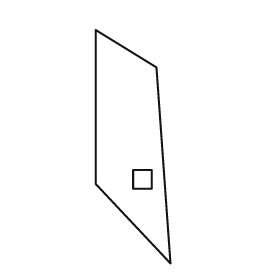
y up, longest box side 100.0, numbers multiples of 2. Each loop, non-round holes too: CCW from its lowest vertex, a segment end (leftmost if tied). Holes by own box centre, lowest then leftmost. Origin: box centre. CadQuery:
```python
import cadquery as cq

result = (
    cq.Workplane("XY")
    .moveTo(16.0, -50.0)
    .lineTo(10.0, 34.0)
    .lineTo(-16.0, 50.0)
    .lineTo(-16.0, -16.0)
    .close()
    .moveTo(0.0, -18.0)
    .lineTo(8.0, -18.0)
    .lineTo(8.0, -10.0)
    .lineTo(0.0, -10.0)
    .close()
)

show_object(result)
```